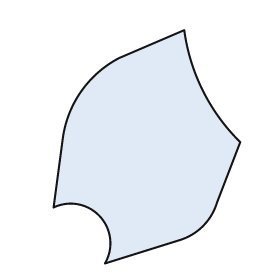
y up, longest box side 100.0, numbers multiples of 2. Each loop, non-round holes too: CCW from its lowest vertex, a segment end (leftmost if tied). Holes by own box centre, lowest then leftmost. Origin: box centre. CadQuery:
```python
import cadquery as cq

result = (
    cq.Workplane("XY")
    .moveTo(-18.0, -50.0)
    .lineTo(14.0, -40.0)
    .threePointArc((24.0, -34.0), (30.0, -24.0))
    .lineTo(40.0, 2.0)
    .threePointArc((24.0, 24.0), (16.0, 50.0))
    .lineTo(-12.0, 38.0)
    .threePointArc((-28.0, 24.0), (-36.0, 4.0))
    .lineTo(-40.0, -26.0)
    .threePointArc((-20.0, -30.0), (-18.0, -50.0))
    .close()
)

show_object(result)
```